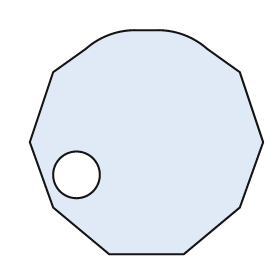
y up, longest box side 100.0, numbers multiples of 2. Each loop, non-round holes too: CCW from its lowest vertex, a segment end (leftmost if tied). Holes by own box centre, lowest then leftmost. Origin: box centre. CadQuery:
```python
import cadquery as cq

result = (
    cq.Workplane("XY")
    .moveTo(-16.0, -48.0)
    .lineTo(16.0, -48.0)
    .lineTo(40.0, -28.0)
    .lineTo(50.0, 0.0)
    .lineTo(40.0, 30.0)
    .lineTo(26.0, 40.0)
    .threePointArc((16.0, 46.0), (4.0, 48.0))
    .lineTo(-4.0, 48.0)
    .threePointArc((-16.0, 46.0), (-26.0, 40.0))
    .lineTo(-40.0, 30.0)
    .lineTo(-50.0, 0.0)
    .lineTo(-40.0, -28.0)
    .close()
    .moveTo(-30.0, -14.0)
    .circle(10.0)
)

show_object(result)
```